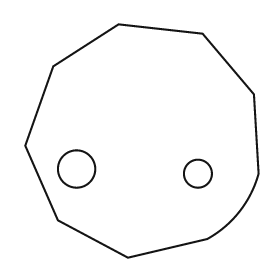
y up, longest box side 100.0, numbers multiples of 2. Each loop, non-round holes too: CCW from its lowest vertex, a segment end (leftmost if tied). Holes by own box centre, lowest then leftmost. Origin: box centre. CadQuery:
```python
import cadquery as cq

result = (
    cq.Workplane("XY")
    .moveTo(-6.0, -50.0)
    .lineTo(28.0, -42.0)
    .threePointArc((42.0, -30.0), (50.0, -14.0))
    .lineTo(48.0, 20.0)
    .lineTo(26.0, 46.0)
    .lineTo(-10.0, 50.0)
    .lineTo(-38.0, 32.0)
    .lineTo(-50.0, -2.0)
    .lineTo(-36.0, -34.0)
    .close()
    .moveTo(24.0, -14.0)
    .circle(6.0)
    .moveTo(-28.0, -12.0)
    .circle(8.0)
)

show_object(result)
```